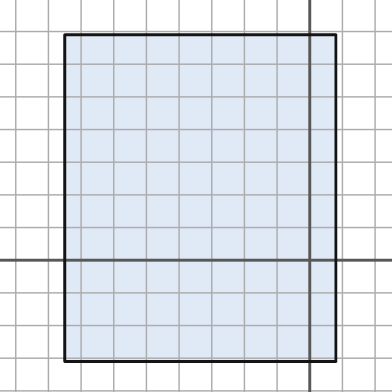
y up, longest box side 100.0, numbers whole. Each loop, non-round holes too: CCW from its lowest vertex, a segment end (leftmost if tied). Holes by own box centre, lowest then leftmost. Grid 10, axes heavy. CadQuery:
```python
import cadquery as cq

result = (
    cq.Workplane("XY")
    .moveTo(-75.0, -31.0)
    .lineTo(8.0, -31.0)
    .lineTo(8.0, 69.0)
    .lineTo(-75.0, 69.0)
    .close()
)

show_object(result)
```